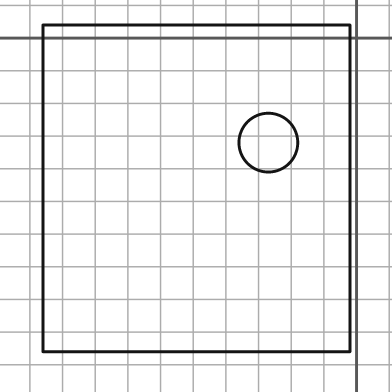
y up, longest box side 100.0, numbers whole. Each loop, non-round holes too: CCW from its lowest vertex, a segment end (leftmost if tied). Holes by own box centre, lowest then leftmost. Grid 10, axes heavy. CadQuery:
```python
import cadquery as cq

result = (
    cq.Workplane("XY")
    .moveTo(-96.0, -96.0)
    .lineTo(-2.0, -96.0)
    .lineTo(-2.0, 4.0)
    .lineTo(-96.0, 4.0)
    .close()
    .moveTo(-27.0, -32.0)
    .circle(9.0)
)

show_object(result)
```